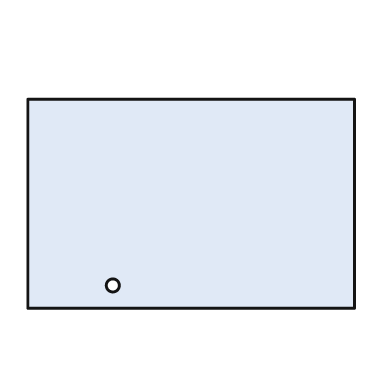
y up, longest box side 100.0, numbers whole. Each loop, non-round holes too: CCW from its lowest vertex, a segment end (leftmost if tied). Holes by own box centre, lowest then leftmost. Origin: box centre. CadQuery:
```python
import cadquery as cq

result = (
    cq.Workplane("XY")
    .moveTo(-50.0, -32.0)
    .lineTo(50.0, -32.0)
    .lineTo(50.0, 32.0)
    .lineTo(-50.0, 32.0)
    .close()
    .moveTo(-24.0, -25.0)
    .circle(2.0)
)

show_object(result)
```